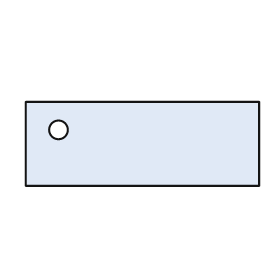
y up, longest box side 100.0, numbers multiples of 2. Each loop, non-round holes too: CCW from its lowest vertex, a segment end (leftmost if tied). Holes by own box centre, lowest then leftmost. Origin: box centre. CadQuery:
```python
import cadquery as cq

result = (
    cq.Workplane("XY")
    .moveTo(-50.0, -18.0)
    .lineTo(50.0, -18.0)
    .lineTo(50.0, 18.0)
    .lineTo(-50.0, 18.0)
    .close()
    .moveTo(-36.0, 6.0)
    .circle(4.0)
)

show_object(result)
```